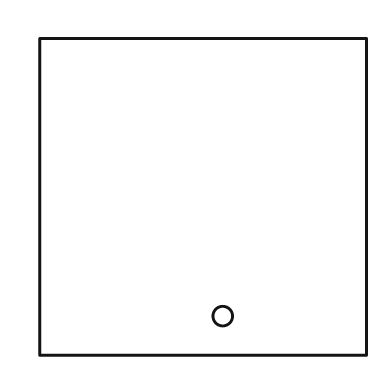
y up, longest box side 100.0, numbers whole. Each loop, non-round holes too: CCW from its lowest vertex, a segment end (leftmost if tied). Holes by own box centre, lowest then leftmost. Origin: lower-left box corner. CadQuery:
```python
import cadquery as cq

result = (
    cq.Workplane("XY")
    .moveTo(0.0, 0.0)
    .lineTo(100.0, 0.0)
    .lineTo(100.0, 97.0)
    .lineTo(0.0, 97.0)
    .close()
    .moveTo(56.0, 12.0)
    .circle(3.0)
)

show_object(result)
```